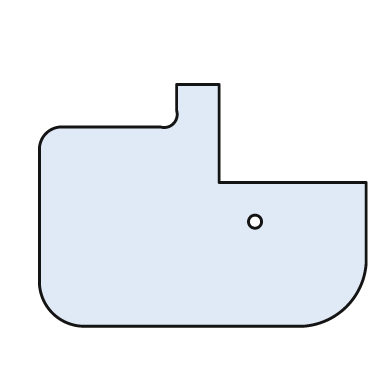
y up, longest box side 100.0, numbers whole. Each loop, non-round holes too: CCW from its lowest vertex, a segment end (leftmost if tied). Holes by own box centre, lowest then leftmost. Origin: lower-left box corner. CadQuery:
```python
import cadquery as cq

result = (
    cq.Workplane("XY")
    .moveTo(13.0, 0.0)
    .lineTo(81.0, 0.0)
    .threePointArc((94.0, 6.0), (100.0, 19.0))
    .lineTo(100.0, 44.0)
    .lineTo(55.0, 44.0)
    .lineTo(55.0, 74.0)
    .lineTo(42.0, 74.0)
    .lineTo(42.0, 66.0)
    .threePointArc((41.0, 62.0), (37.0, 61.0))
    .lineTo(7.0, 61.0)
    .threePointArc((2.0, 59.0), (0.0, 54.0))
    .lineTo(0.0, 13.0)
    .threePointArc((4.0, 4.0), (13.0, 0.0))
    .close()
    .moveTo(66.0, 32.0)
    .circle(2.0)
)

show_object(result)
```